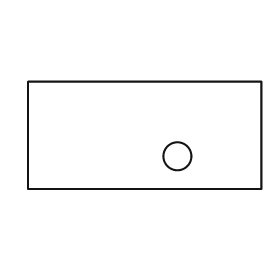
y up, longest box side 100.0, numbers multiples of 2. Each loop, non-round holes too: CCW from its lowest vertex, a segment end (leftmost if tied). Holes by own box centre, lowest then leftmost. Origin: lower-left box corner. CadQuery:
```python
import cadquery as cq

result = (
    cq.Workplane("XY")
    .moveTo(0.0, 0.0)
    .lineTo(100.0, 0.0)
    .lineTo(100.0, 46.0)
    .lineTo(0.0, 46.0)
    .close()
    .moveTo(64.0, 14.0)
    .circle(6.0)
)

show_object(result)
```